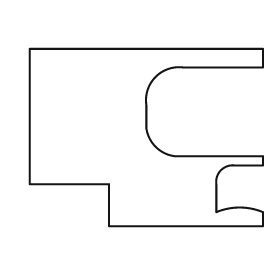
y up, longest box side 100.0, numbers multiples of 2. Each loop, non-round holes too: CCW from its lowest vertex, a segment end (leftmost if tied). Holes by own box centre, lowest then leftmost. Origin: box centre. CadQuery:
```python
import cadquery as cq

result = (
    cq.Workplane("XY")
    .moveTo(-16.0, -38.0)
    .lineTo(50.0, -38.0)
    .lineTo(50.0, -32.0)
    .threePointArc((40.0, -30.0), (30.0, -32.0))
    .lineTo(30.0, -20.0)
    .threePointArc((32.0, -14.0), (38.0, -12.0))
    .lineTo(50.0, -12.0)
    .lineTo(50.0, -8.0)
    .lineTo(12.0, -8.0)
    .threePointArc((4.0, -4.0), (0.0, 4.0))
    .lineTo(0.0, 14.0)
    .threePointArc((4.0, 26.0), (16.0, 30.0))
    .lineTo(50.0, 30.0)
    .lineTo(50.0, 38.0)
    .lineTo(-50.0, 38.0)
    .lineTo(-50.0, -20.0)
    .lineTo(-16.0, -20.0)
    .close()
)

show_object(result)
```